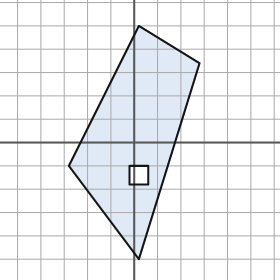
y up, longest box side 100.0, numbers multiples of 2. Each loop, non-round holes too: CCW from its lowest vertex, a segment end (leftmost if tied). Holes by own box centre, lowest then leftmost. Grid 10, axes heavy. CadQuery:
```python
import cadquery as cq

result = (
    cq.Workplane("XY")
    .moveTo(2.0, -50.0)
    .lineTo(28.0, 34.0)
    .lineTo(2.0, 50.0)
    .lineTo(-28.0, -10.0)
    .close()
    .moveTo(-2.0, -18.0)
    .lineTo(6.0, -18.0)
    .lineTo(6.0, -10.0)
    .lineTo(-2.0, -10.0)
    .close()
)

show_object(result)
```